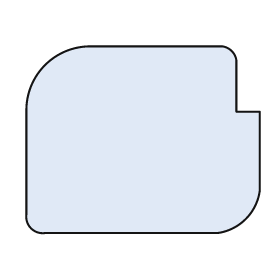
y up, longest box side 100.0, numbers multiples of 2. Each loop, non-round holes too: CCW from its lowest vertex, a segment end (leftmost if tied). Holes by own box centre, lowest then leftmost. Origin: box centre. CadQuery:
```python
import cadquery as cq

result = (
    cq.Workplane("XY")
    .moveTo(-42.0, -40.0)
    .lineTo(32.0, -40.0)
    .threePointArc((44.0, -34.0), (50.0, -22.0))
    .lineTo(50.0, 12.0)
    .lineTo(40.0, 12.0)
    .lineTo(40.0, 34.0)
    .threePointArc((38.0, 38.0), (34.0, 40.0))
    .lineTo(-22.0, 40.0)
    .threePointArc((-42.0, 32.0), (-50.0, 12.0))
    .lineTo(-50.0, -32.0)
    .threePointArc((-48.0, -38.0), (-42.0, -40.0))
    .close()
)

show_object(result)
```